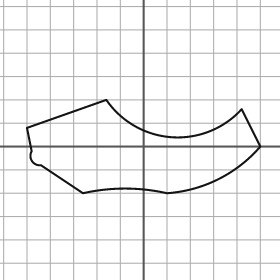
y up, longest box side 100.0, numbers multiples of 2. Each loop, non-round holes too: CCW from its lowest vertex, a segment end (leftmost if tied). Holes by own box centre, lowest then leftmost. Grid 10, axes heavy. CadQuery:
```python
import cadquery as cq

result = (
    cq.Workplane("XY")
    .moveTo(-26.0, -20.0)
    .threePointArc((-8.0, -18.0), (10.0, -20.0))
    .threePointArc((32.0, -14.0), (50.0, 0.0))
    .lineTo(42.0, 16.0)
    .threePointArc((12.0, 4.0), (-16.0, 20.0))
    .lineTo(-50.0, 8.0)
    .lineTo(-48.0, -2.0)
    .threePointArc((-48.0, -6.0), (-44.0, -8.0))
    .close()
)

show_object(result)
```